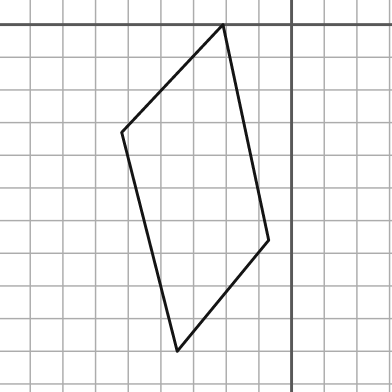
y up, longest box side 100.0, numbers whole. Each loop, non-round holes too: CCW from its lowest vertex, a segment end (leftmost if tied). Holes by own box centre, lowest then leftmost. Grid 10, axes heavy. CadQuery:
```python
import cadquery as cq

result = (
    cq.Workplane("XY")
    .moveTo(-35.0, -100.0)
    .lineTo(-7.0, -66.0)
    .lineTo(-21.0, 0.0)
    .lineTo(-52.0, -33.0)
    .close()
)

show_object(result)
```